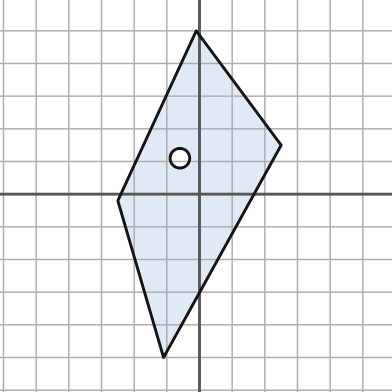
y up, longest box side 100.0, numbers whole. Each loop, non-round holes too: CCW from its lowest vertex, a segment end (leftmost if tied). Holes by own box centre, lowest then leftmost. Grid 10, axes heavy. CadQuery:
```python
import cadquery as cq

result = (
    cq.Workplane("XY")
    .moveTo(-11.0, -50.0)
    .lineTo(25.0, 15.0)
    .lineTo(-1.0, 50.0)
    .lineTo(-25.0, -2.0)
    .close()
    .moveTo(-6.0, 11.0)
    .circle(3.0)
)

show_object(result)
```